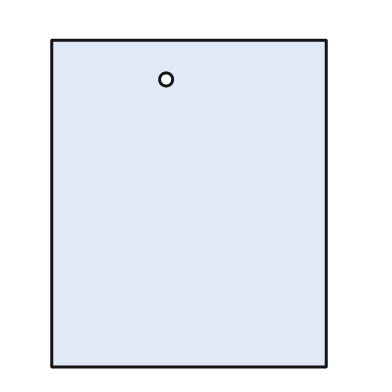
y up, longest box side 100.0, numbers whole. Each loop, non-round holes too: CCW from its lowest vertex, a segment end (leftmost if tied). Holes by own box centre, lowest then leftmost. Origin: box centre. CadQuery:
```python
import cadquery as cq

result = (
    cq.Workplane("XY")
    .moveTo(-42.0, -50.0)
    .lineTo(42.0, -50.0)
    .lineTo(42.0, 50.0)
    .lineTo(-42.0, 50.0)
    .close()
    .moveTo(-7.0, 38.0)
    .circle(2.0)
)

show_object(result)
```